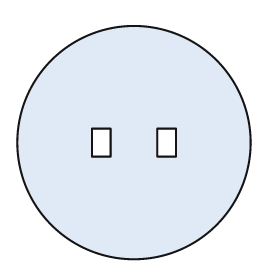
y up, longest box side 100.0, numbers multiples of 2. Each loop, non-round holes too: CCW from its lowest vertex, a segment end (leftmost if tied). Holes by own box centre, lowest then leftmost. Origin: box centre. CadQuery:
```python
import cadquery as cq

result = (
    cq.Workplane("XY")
    .moveTo(0.0, 0.0)
    .circle(50.0)
    .moveTo(-18.0, -6.0)
    .lineTo(-10.0, -6.0)
    .lineTo(-10.0, 6.0)
    .lineTo(-18.0, 6.0)
    .close()
    .moveTo(10.0, -6.0)
    .lineTo(18.0, -6.0)
    .lineTo(18.0, 6.0)
    .lineTo(10.0, 6.0)
    .close()
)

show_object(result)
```